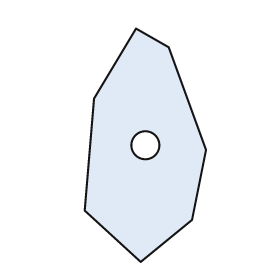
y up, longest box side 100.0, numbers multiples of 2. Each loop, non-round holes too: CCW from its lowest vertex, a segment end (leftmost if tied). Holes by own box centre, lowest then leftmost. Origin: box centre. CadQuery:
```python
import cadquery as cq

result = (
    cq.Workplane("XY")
    .moveTo(-2.0, -50.0)
    .lineTo(20.0, -32.0)
    .lineTo(26.0, -2.0)
    .lineTo(10.0, 42.0)
    .lineTo(-4.0, 50.0)
    .lineTo(-22.0, 20.0)
    .lineTo(-26.0, -28.0)
    .close()
    .moveTo(0.0, 0.0)
    .circle(6.0)
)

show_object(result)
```